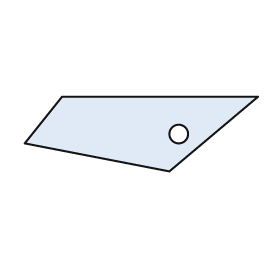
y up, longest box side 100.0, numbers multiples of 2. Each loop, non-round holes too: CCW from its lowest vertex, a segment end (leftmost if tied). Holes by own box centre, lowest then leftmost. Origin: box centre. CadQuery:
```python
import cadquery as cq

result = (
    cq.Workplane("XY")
    .moveTo(12.0, -16.0)
    .lineTo(50.0, 16.0)
    .lineTo(-34.0, 16.0)
    .lineTo(-50.0, -4.0)
    .close()
    .moveTo(16.0, 0.0)
    .circle(4.0)
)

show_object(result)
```